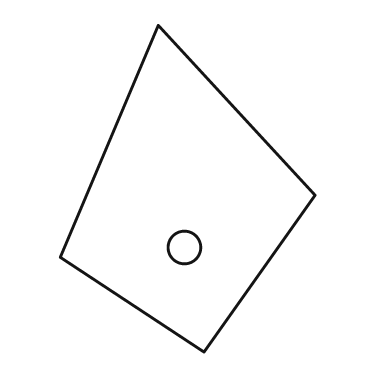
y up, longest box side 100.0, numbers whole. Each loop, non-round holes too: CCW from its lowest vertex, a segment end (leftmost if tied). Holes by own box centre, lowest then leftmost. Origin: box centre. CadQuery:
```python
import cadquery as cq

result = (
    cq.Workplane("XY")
    .moveTo(5.0, -50.0)
    .lineTo(39.0, -2.0)
    .lineTo(-9.0, 50.0)
    .lineTo(-39.0, -21.0)
    .close()
    .moveTo(-1.0, -18.0)
    .circle(5.0)
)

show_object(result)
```